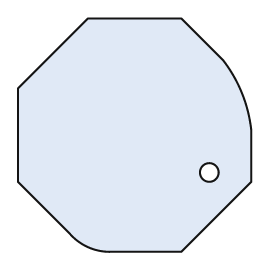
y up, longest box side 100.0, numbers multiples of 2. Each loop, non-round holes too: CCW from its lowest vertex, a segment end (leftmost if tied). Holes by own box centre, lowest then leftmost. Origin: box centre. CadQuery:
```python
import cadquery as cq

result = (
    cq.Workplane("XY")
    .moveTo(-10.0, -50.0)
    .lineTo(20.0, -50.0)
    .lineTo(50.0, -20.0)
    .lineTo(50.0, 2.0)
    .threePointArc((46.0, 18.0), (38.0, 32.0))
    .lineTo(20.0, 50.0)
    .lineTo(-20.0, 50.0)
    .lineTo(-50.0, 20.0)
    .lineTo(-50.0, -20.0)
    .lineTo(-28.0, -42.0)
    .threePointArc((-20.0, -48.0), (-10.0, -50.0))
    .close()
    .moveTo(32.0, -16.0)
    .circle(4.0)
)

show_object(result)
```